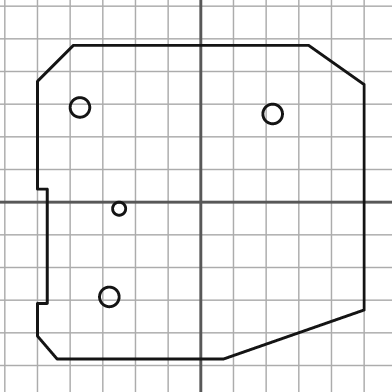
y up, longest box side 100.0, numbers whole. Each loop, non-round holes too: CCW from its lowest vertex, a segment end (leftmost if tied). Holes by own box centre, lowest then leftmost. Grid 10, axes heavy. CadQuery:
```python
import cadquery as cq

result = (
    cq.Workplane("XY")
    .moveTo(-44.0, -48.0)
    .lineTo(7.0, -48.0)
    .lineTo(50.0, -33.0)
    .lineTo(50.0, 36.0)
    .lineTo(33.0, 48.0)
    .lineTo(-39.0, 48.0)
    .lineTo(-50.0, 37.0)
    .lineTo(-50.0, 4.0)
    .lineTo(-47.0, 4.0)
    .lineTo(-47.0, -31.0)
    .lineTo(-50.0, -31.0)
    .lineTo(-50.0, -41.0)
    .close()
    .moveTo(-28.0, -29.0)
    .circle(3.0)
    .moveTo(-25.0, -2.0)
    .circle(2.0)
    .moveTo(22.0, 27.0)
    .circle(3.0)
    .moveTo(-37.0, 29.0)
    .circle(3.0)
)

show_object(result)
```